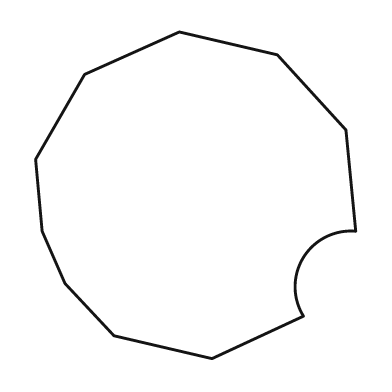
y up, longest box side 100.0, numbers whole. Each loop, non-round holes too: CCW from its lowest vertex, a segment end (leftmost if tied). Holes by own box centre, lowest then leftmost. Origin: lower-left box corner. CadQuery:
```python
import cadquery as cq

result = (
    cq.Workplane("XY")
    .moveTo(54.0, 0.0)
    .lineTo(82.0, 13.0)
    .threePointArc((82.0, 31.0), (98.0, 39.0))
    .lineTo(95.0, 70.0)
    .lineTo(74.0, 93.0)
    .lineTo(44.0, 100.0)
    .lineTo(15.0, 87.0)
    .lineTo(0.0, 61.0)
    .lineTo(2.0, 39.0)
    .lineTo(9.0, 23.0)
    .lineTo(24.0, 7.0)
    .close()
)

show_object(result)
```